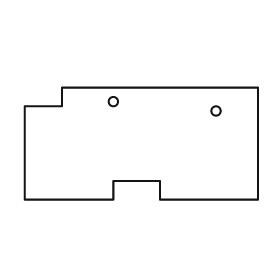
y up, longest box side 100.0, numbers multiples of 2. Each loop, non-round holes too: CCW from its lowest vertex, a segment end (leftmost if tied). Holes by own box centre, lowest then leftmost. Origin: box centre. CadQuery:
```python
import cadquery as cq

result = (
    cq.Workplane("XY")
    .moveTo(-50.0, -24.0)
    .lineTo(-12.0, -24.0)
    .lineTo(-12.0, -16.0)
    .lineTo(8.0, -16.0)
    .lineTo(8.0, -24.0)
    .lineTo(50.0, -24.0)
    .lineTo(50.0, 24.0)
    .lineTo(-34.0, 24.0)
    .lineTo(-34.0, 16.0)
    .lineTo(-50.0, 16.0)
    .close()
    .moveTo(32.0, 14.0)
    .circle(2.0)
    .moveTo(-12.0, 18.0)
    .circle(2.0)
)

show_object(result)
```